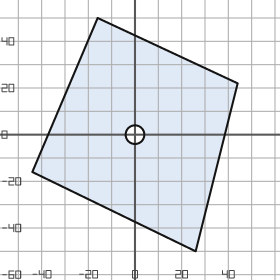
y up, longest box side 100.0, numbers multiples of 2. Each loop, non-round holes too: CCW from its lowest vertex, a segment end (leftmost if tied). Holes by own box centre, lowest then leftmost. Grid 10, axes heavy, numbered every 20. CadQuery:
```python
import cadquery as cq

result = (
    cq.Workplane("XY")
    .moveTo(26.0, -50.0)
    .lineTo(44.0, 22.0)
    .lineTo(-16.0, 50.0)
    .lineTo(-44.0, -16.0)
    .close()
    .moveTo(0.0, 0.0)
    .circle(4.0)
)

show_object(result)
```